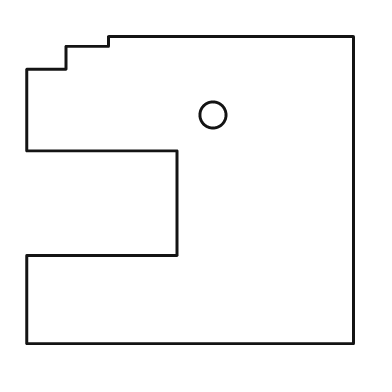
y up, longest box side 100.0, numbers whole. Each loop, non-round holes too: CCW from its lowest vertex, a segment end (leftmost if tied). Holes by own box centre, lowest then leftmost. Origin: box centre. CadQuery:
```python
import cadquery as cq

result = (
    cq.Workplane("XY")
    .moveTo(-50.0, -47.0)
    .lineTo(50.0, -47.0)
    .lineTo(50.0, 47.0)
    .lineTo(-25.0, 47.0)
    .lineTo(-25.0, 44.0)
    .lineTo(-38.0, 44.0)
    .lineTo(-38.0, 37.0)
    .lineTo(-50.0, 37.0)
    .lineTo(-50.0, 12.0)
    .lineTo(-4.0, 12.0)
    .lineTo(-4.0, -20.0)
    .lineTo(-50.0, -20.0)
    .close()
    .moveTo(7.0, 23.0)
    .circle(4.0)
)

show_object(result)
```